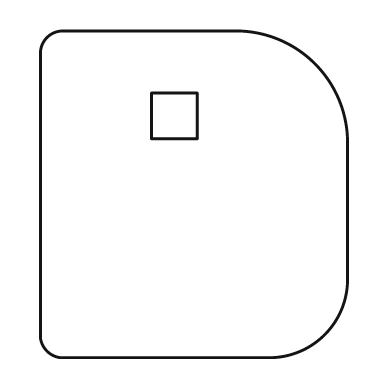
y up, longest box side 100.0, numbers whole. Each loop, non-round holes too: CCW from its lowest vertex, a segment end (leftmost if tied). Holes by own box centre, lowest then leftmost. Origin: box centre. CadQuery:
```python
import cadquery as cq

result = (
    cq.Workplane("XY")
    .moveTo(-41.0, -50.0)
    .lineTo(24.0, -50.0)
    .threePointArc((40.0, -43.0), (47.0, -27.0))
    .lineTo(47.0, 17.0)
    .threePointArc((37.0, 40.0), (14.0, 50.0))
    .lineTo(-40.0, 50.0)
    .threePointArc((-45.0, 48.0), (-47.0, 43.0))
    .lineTo(-47.0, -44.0)
    .threePointArc((-45.0, -48.0), (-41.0, -50.0))
    .close()
    .moveTo(-13.0, 17.0)
    .lineTo(1.0, 17.0)
    .lineTo(1.0, 31.0)
    .lineTo(-13.0, 31.0)
    .close()
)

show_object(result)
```